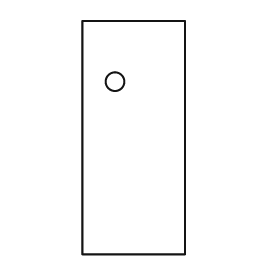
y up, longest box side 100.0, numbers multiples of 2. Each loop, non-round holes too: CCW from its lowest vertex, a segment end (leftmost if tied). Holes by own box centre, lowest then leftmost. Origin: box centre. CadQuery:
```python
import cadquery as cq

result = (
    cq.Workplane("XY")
    .moveTo(-22.0, -50.0)
    .lineTo(22.0, -50.0)
    .lineTo(22.0, 50.0)
    .lineTo(-22.0, 50.0)
    .close()
    .moveTo(-8.0, 24.0)
    .circle(4.0)
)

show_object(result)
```